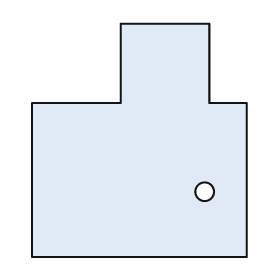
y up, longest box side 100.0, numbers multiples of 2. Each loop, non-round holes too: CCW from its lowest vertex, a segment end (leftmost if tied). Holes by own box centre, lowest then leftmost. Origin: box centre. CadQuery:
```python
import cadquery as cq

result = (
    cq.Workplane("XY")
    .moveTo(-46.0, -50.0)
    .lineTo(46.0, -50.0)
    .lineTo(46.0, 16.0)
    .lineTo(30.0, 16.0)
    .lineTo(30.0, 50.0)
    .lineTo(-8.0, 50.0)
    .lineTo(-8.0, 16.0)
    .lineTo(-46.0, 16.0)
    .close()
    .moveTo(28.0, -22.0)
    .circle(4.0)
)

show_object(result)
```